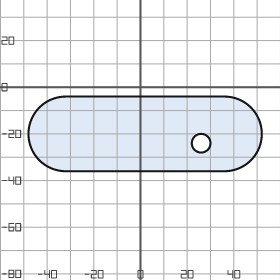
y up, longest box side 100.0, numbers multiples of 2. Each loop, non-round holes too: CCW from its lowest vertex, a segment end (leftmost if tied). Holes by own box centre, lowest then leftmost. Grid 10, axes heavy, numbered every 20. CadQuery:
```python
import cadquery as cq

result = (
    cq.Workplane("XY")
    .moveTo(-32.0, -36.0)
    .lineTo(36.0, -36.0)
    .threePointArc((52.0, -20.0), (36.0, -4.0))
    .lineTo(-32.0, -4.0)
    .threePointArc((-48.0, -20.0), (-32.0, -36.0))
    .close()
    .moveTo(26.0, -24.0)
    .circle(4.0)
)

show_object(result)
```